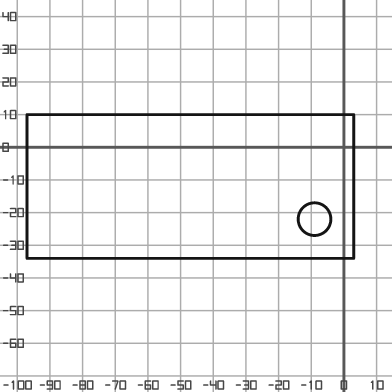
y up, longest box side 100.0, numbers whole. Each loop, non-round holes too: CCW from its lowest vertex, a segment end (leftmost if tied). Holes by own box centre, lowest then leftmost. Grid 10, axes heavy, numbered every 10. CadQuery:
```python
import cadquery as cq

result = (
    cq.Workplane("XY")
    .moveTo(-97.0, -34.0)
    .lineTo(3.0, -34.0)
    .lineTo(3.0, 10.0)
    .lineTo(-97.0, 10.0)
    .close()
    .moveTo(-9.0, -22.0)
    .circle(5.0)
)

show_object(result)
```